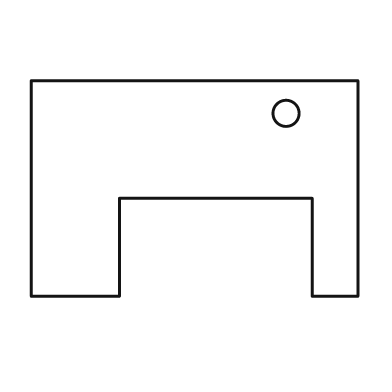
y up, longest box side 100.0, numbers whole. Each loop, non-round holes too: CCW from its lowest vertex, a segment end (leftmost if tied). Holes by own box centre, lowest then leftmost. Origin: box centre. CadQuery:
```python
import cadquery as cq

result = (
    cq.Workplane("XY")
    .moveTo(-50.0, -33.0)
    .lineTo(-23.0, -33.0)
    .lineTo(-23.0, -3.0)
    .lineTo(36.0, -3.0)
    .lineTo(36.0, -33.0)
    .lineTo(50.0, -33.0)
    .lineTo(50.0, 33.0)
    .lineTo(-50.0, 33.0)
    .close()
    .moveTo(28.0, 23.0)
    .circle(4.0)
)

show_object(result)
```